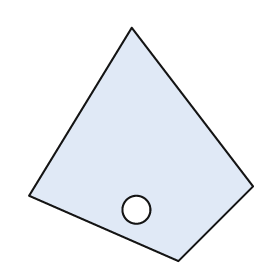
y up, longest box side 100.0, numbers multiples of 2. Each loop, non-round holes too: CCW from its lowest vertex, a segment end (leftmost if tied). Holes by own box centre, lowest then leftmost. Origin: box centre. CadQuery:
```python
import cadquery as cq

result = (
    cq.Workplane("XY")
    .moveTo(16.0, -50.0)
    .lineTo(48.0, -18.0)
    .lineTo(-4.0, 50.0)
    .lineTo(-48.0, -22.0)
    .close()
    .moveTo(-2.0, -28.0)
    .circle(6.0)
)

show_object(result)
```